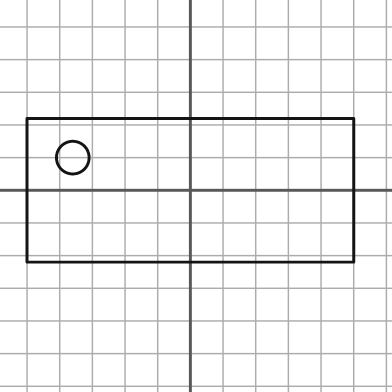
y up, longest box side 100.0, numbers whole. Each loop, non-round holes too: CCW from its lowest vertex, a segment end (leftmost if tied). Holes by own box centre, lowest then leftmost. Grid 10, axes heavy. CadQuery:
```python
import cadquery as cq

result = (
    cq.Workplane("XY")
    .moveTo(-50.0, -22.0)
    .lineTo(50.0, -22.0)
    .lineTo(50.0, 22.0)
    .lineTo(-50.0, 22.0)
    .close()
    .moveTo(-36.0, 10.0)
    .circle(5.0)
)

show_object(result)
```